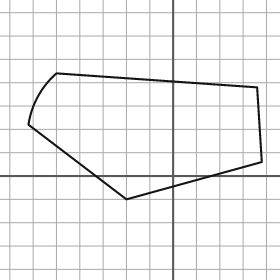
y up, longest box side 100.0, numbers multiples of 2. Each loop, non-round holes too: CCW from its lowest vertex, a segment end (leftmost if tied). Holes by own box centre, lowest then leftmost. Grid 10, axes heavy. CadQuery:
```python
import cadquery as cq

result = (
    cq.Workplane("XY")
    .moveTo(-20.0, -10.0)
    .lineTo(38.0, 6.0)
    .lineTo(36.0, 38.0)
    .lineTo(-50.0, 44.0)
    .threePointArc((-58.0, 34.0), (-62.0, 22.0))
    .close()
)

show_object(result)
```